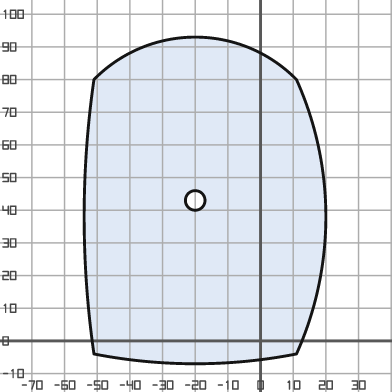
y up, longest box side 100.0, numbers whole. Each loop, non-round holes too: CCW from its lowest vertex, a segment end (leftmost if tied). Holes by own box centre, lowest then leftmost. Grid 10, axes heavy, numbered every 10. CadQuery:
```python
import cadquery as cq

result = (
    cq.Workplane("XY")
    .moveTo(-51.0, -4.0)
    .threePointArc((-20.0, -7.0), (11.0, -4.0))
    .threePointArc((20.0, 38.0), (11.0, 80.0))
    .threePointArc((-20.0, 93.0), (-51.0, 80.0))
    .threePointArc((-54.0, 38.0), (-51.0, -4.0))
    .close()
    .moveTo(-20.0, 43.0)
    .circle(3.0)
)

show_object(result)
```